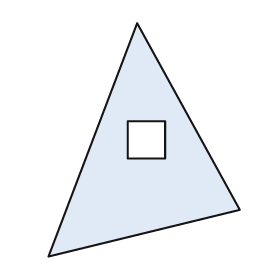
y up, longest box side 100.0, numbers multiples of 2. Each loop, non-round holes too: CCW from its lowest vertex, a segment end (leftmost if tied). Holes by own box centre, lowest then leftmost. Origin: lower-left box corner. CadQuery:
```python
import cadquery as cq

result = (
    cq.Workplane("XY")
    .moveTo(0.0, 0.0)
    .lineTo(82.0, 20.0)
    .lineTo(38.0, 100.0)
    .close()
    .moveTo(34.0, 42.0)
    .lineTo(50.0, 42.0)
    .lineTo(50.0, 58.0)
    .lineTo(34.0, 58.0)
    .close()
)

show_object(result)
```